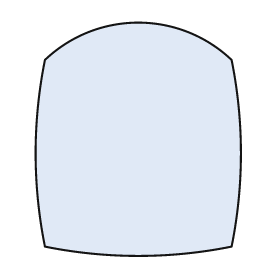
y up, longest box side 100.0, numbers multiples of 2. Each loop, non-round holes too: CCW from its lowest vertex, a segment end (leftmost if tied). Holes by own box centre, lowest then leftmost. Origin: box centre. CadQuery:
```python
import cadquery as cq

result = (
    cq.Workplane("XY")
    .moveTo(-40.0, -46.0)
    .threePointArc((0.0, -50.0), (40.0, -46.0))
    .threePointArc((44.0, -6.0), (40.0, 34.0))
    .threePointArc((0.0, 50.0), (-40.0, 34.0))
    .threePointArc((-44.0, -6.0), (-40.0, -46.0))
    .close()
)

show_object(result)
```